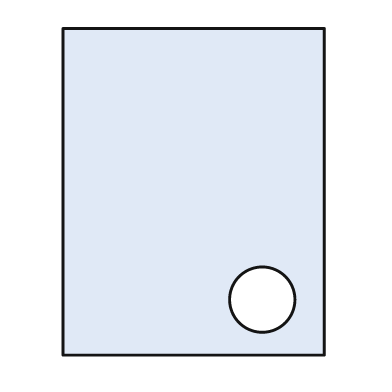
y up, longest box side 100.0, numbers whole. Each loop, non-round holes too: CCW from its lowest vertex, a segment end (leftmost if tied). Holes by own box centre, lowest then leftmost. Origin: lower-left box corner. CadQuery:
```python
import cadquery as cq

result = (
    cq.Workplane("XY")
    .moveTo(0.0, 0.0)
    .lineTo(80.0, 0.0)
    .lineTo(80.0, 100.0)
    .lineTo(0.0, 100.0)
    .close()
    .moveTo(61.0, 17.0)
    .circle(10.0)
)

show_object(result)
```